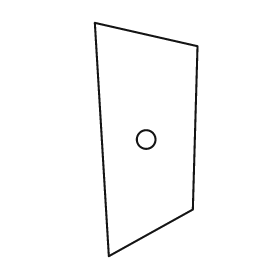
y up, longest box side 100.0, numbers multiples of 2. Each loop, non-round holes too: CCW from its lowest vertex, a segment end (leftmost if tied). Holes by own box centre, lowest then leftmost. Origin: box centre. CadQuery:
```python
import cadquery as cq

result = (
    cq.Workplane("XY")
    .moveTo(-16.0, -50.0)
    .lineTo(20.0, -30.0)
    .lineTo(22.0, 40.0)
    .lineTo(-22.0, 50.0)
    .close()
    .moveTo(0.0, 0.0)
    .circle(4.0)
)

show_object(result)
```